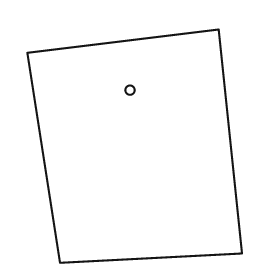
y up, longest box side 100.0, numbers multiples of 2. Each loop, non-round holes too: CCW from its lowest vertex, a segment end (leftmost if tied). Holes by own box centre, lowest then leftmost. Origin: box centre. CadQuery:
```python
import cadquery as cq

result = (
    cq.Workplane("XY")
    .moveTo(-32.0, -50.0)
    .lineTo(46.0, -46.0)
    .lineTo(36.0, 50.0)
    .lineTo(-46.0, 40.0)
    .close()
    .moveTo(-2.0, 24.0)
    .circle(2.0)
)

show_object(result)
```